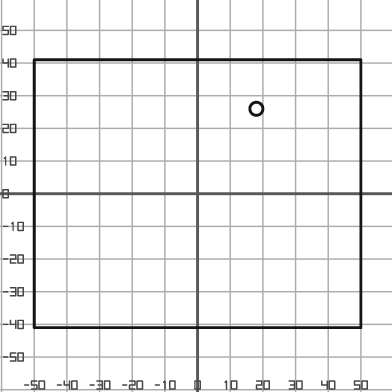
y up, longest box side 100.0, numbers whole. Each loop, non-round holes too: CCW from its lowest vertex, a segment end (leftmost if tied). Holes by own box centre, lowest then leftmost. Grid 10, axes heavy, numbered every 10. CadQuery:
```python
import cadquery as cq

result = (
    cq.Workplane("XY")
    .moveTo(-50.0, -41.0)
    .lineTo(50.0, -41.0)
    .lineTo(50.0, 41.0)
    .lineTo(-50.0, 41.0)
    .close()
    .moveTo(18.0, 26.0)
    .circle(2.0)
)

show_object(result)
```